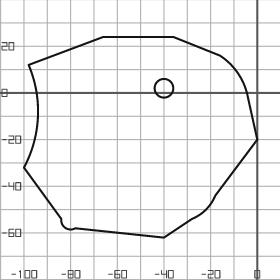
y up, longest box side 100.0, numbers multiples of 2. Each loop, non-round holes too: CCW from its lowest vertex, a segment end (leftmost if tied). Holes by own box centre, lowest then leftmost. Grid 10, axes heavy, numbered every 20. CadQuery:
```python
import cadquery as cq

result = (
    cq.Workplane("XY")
    .moveTo(-40.0, -62.0)
    .lineTo(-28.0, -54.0)
    .threePointArc((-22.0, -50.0), (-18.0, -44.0))
    .lineTo(0.0, -20.0)
    .lineTo(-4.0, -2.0)
    .threePointArc((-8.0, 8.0), (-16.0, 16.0))
    .lineTo(-36.0, 24.0)
    .lineTo(-66.0, 24.0)
    .lineTo(-98.0, 12.0)
    .threePointArc((-94.0, -10.0), (-100.0, -32.0))
    .lineTo(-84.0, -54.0)
    .threePointArc((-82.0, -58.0), (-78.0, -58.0))
    .close()
    .moveTo(-40.0, 2.0)
    .circle(4.0)
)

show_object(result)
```